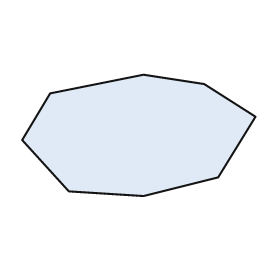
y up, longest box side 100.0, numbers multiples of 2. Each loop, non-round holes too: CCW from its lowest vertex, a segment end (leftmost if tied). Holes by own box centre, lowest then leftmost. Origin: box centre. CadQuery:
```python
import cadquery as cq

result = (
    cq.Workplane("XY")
    .moveTo(2.0, -26.0)
    .lineTo(34.0, -18.0)
    .lineTo(50.0, 8.0)
    .lineTo(28.0, 22.0)
    .lineTo(2.0, 26.0)
    .lineTo(-38.0, 18.0)
    .lineTo(-50.0, -2.0)
    .lineTo(-30.0, -24.0)
    .close()
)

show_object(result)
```